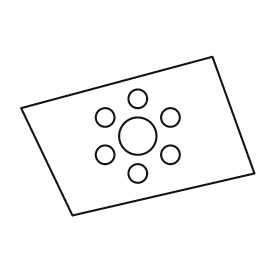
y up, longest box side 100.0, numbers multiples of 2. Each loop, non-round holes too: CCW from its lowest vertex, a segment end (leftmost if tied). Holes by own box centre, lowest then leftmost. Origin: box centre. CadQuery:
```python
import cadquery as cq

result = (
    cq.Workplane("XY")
    .moveTo(-28.0, -34.0)
    .lineTo(50.0, -16.0)
    .lineTo(32.0, 34.0)
    .lineTo(-50.0, 12.0)
    .close()
    .moveTo(0.0, -16.0)
    .circle(4.0)
    .moveTo(-14.0, -8.0)
    .circle(4.0)
    .moveTo(14.0, -8.0)
    .circle(4.0)
    .moveTo(0.0, 0.0)
    .circle(8.0)
    .moveTo(-14.0, 8.0)
    .circle(4.0)
    .moveTo(14.0, 8.0)
    .circle(4.0)
    .moveTo(0.0, 16.0)
    .circle(4.0)
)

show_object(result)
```